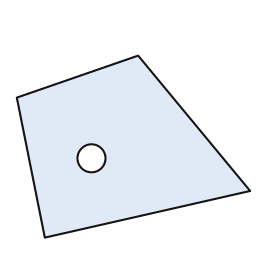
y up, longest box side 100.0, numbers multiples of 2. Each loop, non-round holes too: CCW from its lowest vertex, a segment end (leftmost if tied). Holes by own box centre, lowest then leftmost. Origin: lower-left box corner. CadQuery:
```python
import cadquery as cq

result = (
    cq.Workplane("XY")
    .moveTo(12.0, 0.0)
    .lineTo(100.0, 20.0)
    .lineTo(52.0, 78.0)
    .lineTo(0.0, 60.0)
    .close()
    .moveTo(32.0, 34.0)
    .circle(6.0)
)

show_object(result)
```